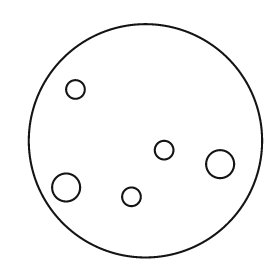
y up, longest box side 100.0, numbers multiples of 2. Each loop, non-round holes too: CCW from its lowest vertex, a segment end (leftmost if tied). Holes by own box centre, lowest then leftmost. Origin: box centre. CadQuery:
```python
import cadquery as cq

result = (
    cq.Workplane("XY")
    .moveTo(0.0, 0.0)
    .circle(50.0)
    .moveTo(-6.0, -24.0)
    .circle(4.0)
    .moveTo(-34.0, -20.0)
    .circle(6.0)
    .moveTo(32.0, -10.0)
    .circle(6.0)
    .moveTo(8.0, -4.0)
    .circle(4.0)
    .moveTo(-30.0, 22.0)
    .circle(4.0)
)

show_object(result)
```